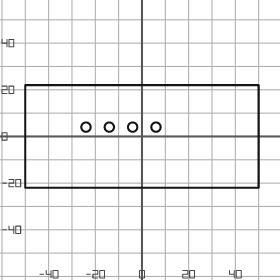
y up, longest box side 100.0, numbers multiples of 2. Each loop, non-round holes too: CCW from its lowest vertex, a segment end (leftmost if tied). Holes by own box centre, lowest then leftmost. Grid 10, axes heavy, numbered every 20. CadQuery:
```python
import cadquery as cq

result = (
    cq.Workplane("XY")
    .moveTo(-50.0, -22.0)
    .lineTo(50.0, -22.0)
    .lineTo(50.0, 22.0)
    .lineTo(-50.0, 22.0)
    .close()
    .moveTo(-24.0, 4.0)
    .circle(2.0)
    .moveTo(-14.0, 4.0)
    .circle(2.0)
    .moveTo(-4.0, 4.0)
    .circle(2.0)
    .moveTo(6.0, 4.0)
    .circle(2.0)
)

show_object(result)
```